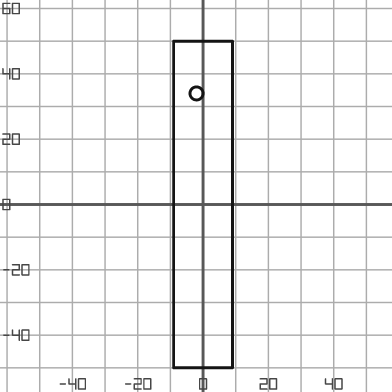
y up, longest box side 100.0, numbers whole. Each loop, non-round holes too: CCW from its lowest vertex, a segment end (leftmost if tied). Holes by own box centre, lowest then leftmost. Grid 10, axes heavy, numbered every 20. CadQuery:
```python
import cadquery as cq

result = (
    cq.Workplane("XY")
    .moveTo(-9.0, -50.0)
    .lineTo(9.0, -50.0)
    .lineTo(9.0, 50.0)
    .lineTo(-9.0, 50.0)
    .close()
    .moveTo(-2.0, 34.0)
    .circle(2.0)
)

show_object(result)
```